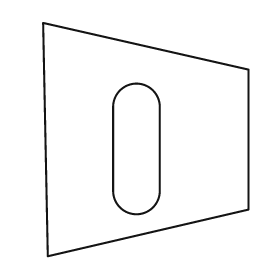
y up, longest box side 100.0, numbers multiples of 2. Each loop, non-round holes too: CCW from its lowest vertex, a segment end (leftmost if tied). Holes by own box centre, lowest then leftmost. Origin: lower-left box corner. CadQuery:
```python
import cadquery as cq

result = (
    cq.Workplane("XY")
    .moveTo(2.0, 0.0)
    .lineTo(88.0, 20.0)
    .lineTo(88.0, 80.0)
    .lineTo(0.0, 100.0)
    .close()
    .moveTo(30.0, 28.0)
    .threePointArc((40.0, 18.0), (50.0, 28.0))
    .lineTo(50.0, 64.0)
    .threePointArc((40.0, 74.0), (30.0, 64.0))
    .close()
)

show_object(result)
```